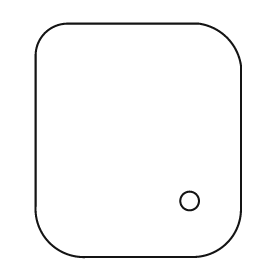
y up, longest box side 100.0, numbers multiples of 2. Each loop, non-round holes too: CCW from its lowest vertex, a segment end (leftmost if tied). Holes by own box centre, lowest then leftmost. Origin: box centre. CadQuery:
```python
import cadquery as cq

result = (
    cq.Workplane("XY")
    .moveTo(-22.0, -50.0)
    .lineTo(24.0, -50.0)
    .threePointArc((38.0, -44.0), (44.0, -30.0))
    .lineTo(44.0, 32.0)
    .threePointArc((38.0, 44.0), (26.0, 50.0))
    .lineTo(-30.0, 50.0)
    .threePointArc((-40.0, 46.0), (-44.0, 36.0))
    .lineTo(-44.0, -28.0)
    .threePointArc((-38.0, -44.0), (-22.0, -50.0))
    .close()
    .moveTo(22.0, -26.0)
    .circle(4.0)
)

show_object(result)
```